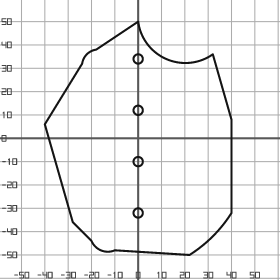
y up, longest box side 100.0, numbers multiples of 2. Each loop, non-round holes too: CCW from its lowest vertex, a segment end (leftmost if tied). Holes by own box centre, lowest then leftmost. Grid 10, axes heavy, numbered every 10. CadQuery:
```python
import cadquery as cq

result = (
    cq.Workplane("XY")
    .moveTo(22.0, -50.0)
    .threePointArc((32.0, -42.0), (40.0, -32.0))
    .lineTo(40.0, 8.0)
    .lineTo(32.0, 36.0)
    .threePointArc((12.0, 34.0), (0.0, 50.0))
    .lineTo(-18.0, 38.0)
    .threePointArc((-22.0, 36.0), (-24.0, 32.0))
    .lineTo(-40.0, 6.0)
    .lineTo(-28.0, -36.0)
    .lineTo(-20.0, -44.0)
    .threePointArc((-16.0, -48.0), (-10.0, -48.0))
    .close()
    .moveTo(0.0, -32.0)
    .circle(2.0)
    .moveTo(0.0, -10.0)
    .circle(2.0)
    .moveTo(0.0, 12.0)
    .circle(2.0)
    .moveTo(0.0, 34.0)
    .circle(2.0)
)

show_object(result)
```